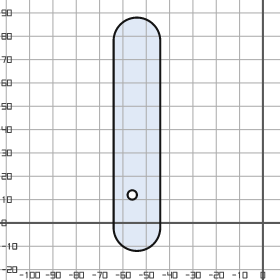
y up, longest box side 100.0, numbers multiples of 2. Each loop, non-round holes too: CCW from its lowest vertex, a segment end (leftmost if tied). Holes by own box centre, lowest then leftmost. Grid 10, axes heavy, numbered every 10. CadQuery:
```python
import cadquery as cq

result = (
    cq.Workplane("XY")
    .moveTo(-64.0, -2.0)
    .threePointArc((-54.0, -12.0), (-44.0, -2.0))
    .lineTo(-44.0, 78.0)
    .threePointArc((-54.0, 88.0), (-64.0, 78.0))
    .close()
    .moveTo(-56.0, 12.0)
    .circle(2.0)
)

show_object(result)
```